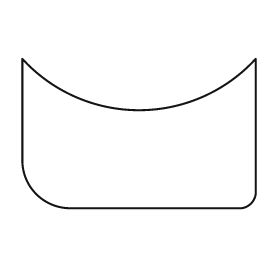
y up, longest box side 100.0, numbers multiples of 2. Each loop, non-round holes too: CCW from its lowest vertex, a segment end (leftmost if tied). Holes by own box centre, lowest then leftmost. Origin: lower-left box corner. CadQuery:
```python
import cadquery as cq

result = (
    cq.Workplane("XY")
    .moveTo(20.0, 0.0)
    .lineTo(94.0, 0.0)
    .threePointArc((98.0, 2.0), (100.0, 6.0))
    .lineTo(100.0, 64.0)
    .threePointArc((50.0, 42.0), (0.0, 64.0))
    .lineTo(0.0, 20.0)
    .threePointArc((6.0, 6.0), (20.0, 0.0))
    .close()
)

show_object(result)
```